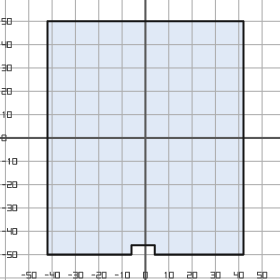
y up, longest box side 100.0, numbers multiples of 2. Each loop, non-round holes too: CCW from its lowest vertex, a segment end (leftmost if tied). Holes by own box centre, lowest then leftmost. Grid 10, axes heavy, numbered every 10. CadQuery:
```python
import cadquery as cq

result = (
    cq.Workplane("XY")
    .moveTo(-42.0, -50.0)
    .lineTo(-6.0, -50.0)
    .lineTo(-6.0, -46.0)
    .lineTo(4.0, -46.0)
    .lineTo(4.0, -50.0)
    .lineTo(42.0, -50.0)
    .lineTo(42.0, 50.0)
    .lineTo(-42.0, 50.0)
    .close()
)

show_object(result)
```